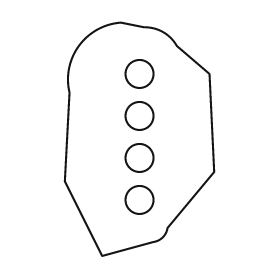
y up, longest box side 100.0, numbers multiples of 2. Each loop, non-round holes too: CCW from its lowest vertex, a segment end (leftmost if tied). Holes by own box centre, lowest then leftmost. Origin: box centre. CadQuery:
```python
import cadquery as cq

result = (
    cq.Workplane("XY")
    .moveTo(-16.0, -50.0)
    .lineTo(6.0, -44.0)
    .threePointArc((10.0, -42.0), (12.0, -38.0))
    .lineTo(32.0, -14.0)
    .lineTo(30.0, 28.0)
    .lineTo(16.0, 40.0)
    .threePointArc((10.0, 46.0), (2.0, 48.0))
    .lineTo(-8.0, 50.0)
    .threePointArc((-26.0, 40.0), (-30.0, 20.0))
    .lineTo(-32.0, -18.0)
    .close()
    .moveTo(0.0, -26.0)
    .circle(6.0)
    .moveTo(0.0, -8.0)
    .circle(6.0)
    .moveTo(0.0, 10.0)
    .circle(6.0)
    .moveTo(0.0, 28.0)
    .circle(6.0)
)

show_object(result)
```